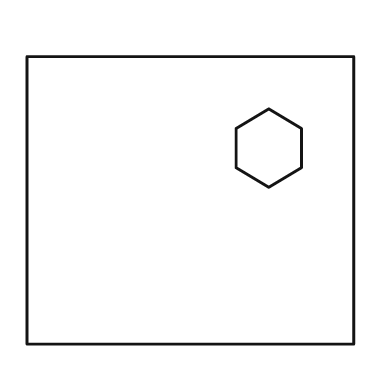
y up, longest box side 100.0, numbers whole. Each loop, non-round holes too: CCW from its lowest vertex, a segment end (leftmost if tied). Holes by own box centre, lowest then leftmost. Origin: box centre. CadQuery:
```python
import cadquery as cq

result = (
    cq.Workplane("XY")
    .moveTo(-50.0, -44.0)
    .lineTo(50.0, -44.0)
    .lineTo(50.0, 44.0)
    .lineTo(-50.0, 44.0)
    .close()
    .moveTo(24.0, 4.0)
    .lineTo(34.0, 10.0)
    .lineTo(34.0, 22.0)
    .lineTo(24.0, 28.0)
    .lineTo(14.0, 22.0)
    .lineTo(14.0, 10.0)
    .close()
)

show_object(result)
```